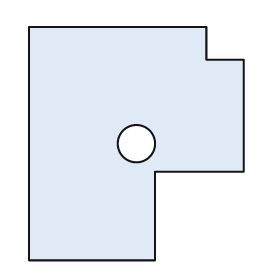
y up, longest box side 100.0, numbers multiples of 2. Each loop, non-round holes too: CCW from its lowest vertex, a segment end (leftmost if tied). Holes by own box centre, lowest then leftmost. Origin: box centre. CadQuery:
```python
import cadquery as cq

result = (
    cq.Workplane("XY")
    .moveTo(-46.0, -50.0)
    .lineTo(8.0, -50.0)
    .lineTo(8.0, -12.0)
    .lineTo(46.0, -12.0)
    .lineTo(46.0, 36.0)
    .lineTo(30.0, 36.0)
    .lineTo(30.0, 50.0)
    .lineTo(-46.0, 50.0)
    .close()
    .moveTo(0.0, 0.0)
    .circle(8.0)
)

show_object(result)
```